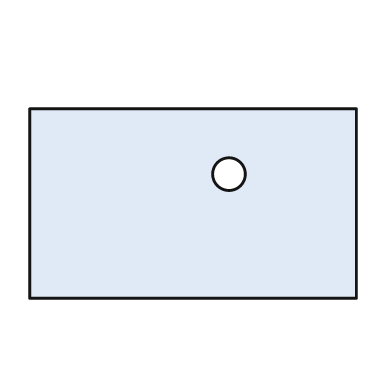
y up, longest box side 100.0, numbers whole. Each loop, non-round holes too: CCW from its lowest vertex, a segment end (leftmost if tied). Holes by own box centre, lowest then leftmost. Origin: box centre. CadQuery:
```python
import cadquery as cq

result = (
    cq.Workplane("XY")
    .moveTo(-50.0, -29.0)
    .lineTo(50.0, -29.0)
    .lineTo(50.0, 29.0)
    .lineTo(-50.0, 29.0)
    .close()
    .moveTo(11.0, 9.0)
    .circle(5.0)
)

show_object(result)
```